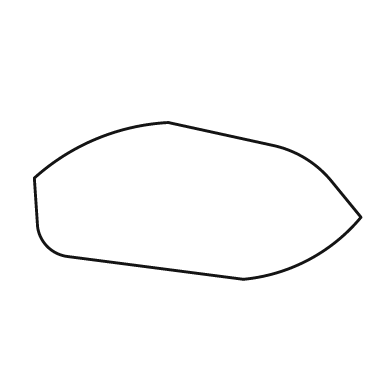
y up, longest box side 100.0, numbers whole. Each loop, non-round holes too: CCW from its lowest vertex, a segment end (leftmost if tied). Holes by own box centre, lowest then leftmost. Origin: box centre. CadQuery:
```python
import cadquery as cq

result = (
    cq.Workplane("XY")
    .moveTo(14.0, -24.0)
    .threePointArc((34.0, -18.0), (50.0, -5.0))
    .lineTo(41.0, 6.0)
    .threePointArc((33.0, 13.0), (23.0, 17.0))
    .lineTo(-9.0, 24.0)
    .threePointArc((-31.0, 19.0), (-50.0, 7.0))
    .lineTo(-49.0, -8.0)
    .threePointArc((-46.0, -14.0), (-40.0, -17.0))
    .close()
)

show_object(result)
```